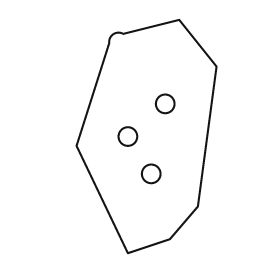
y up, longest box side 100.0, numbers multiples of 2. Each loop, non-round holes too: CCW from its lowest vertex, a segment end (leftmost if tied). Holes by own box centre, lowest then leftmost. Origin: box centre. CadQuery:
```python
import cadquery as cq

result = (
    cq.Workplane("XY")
    .moveTo(-8.0, -50.0)
    .lineTo(10.0, -44.0)
    .lineTo(22.0, -30.0)
    .lineTo(30.0, 30.0)
    .lineTo(14.0, 50.0)
    .lineTo(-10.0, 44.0)
    .threePointArc((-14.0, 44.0), (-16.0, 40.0))
    .lineTo(-30.0, -4.0)
    .close()
    .moveTo(2.0, -16.0)
    .circle(4.0)
    .moveTo(-8.0, 0.0)
    .circle(4.0)
    .moveTo(8.0, 14.0)
    .circle(4.0)
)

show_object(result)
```